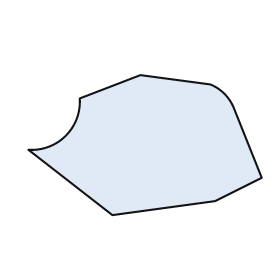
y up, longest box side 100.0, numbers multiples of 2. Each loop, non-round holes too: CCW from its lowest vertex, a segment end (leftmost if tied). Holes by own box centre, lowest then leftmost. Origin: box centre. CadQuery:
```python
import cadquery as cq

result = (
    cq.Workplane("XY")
    .moveTo(-14.0, -30.0)
    .lineTo(30.0, -24.0)
    .lineTo(50.0, -14.0)
    .lineTo(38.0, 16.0)
    .threePointArc((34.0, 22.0), (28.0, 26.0))
    .lineTo(-2.0, 30.0)
    .lineTo(-28.0, 20.0)
    .threePointArc((-34.0, 4.0), (-50.0, -2.0))
    .close()
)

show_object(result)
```